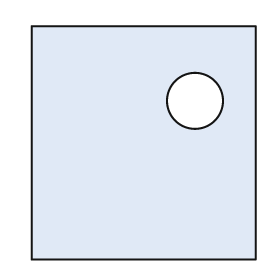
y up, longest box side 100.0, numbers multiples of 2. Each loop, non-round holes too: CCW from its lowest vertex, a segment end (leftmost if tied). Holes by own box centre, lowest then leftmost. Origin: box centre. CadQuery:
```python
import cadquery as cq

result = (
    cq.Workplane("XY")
    .moveTo(-48.0, -50.0)
    .lineTo(48.0, -50.0)
    .lineTo(48.0, 50.0)
    .lineTo(-48.0, 50.0)
    .close()
    .moveTo(22.0, 18.0)
    .circle(12.0)
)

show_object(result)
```